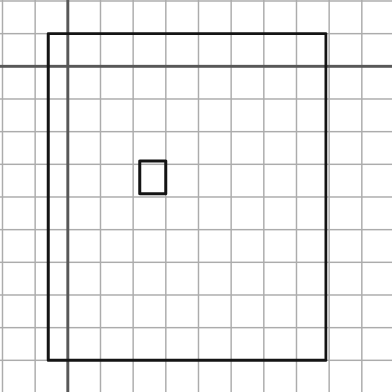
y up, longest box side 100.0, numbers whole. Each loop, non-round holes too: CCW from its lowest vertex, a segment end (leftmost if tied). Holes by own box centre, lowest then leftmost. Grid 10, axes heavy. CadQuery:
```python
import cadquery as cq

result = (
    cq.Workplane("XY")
    .moveTo(-6.0, -90.0)
    .lineTo(79.0, -90.0)
    .lineTo(79.0, 10.0)
    .lineTo(-6.0, 10.0)
    .close()
    .moveTo(22.0, -39.0)
    .lineTo(30.0, -39.0)
    .lineTo(30.0, -29.0)
    .lineTo(22.0, -29.0)
    .close()
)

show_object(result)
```